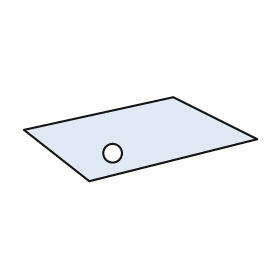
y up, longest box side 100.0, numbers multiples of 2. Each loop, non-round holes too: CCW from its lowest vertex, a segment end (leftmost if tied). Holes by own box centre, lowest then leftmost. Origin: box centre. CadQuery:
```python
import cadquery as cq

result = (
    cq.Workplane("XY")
    .moveTo(-22.0, -18.0)
    .lineTo(50.0, 0.0)
    .lineTo(14.0, 18.0)
    .lineTo(-50.0, 4.0)
    .close()
    .moveTo(-12.0, -6.0)
    .circle(4.0)
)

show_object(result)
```